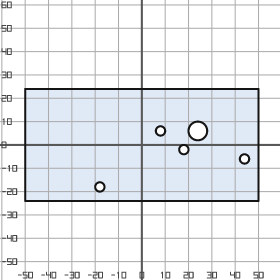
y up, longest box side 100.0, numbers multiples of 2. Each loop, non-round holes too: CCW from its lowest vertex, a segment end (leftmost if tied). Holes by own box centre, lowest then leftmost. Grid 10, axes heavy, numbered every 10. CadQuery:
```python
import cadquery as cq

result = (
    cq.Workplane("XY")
    .moveTo(-50.0, -24.0)
    .lineTo(50.0, -24.0)
    .lineTo(50.0, 24.0)
    .lineTo(-50.0, 24.0)
    .close()
    .moveTo(-18.0, -18.0)
    .circle(2.0)
    .moveTo(44.0, -6.0)
    .circle(2.0)
    .moveTo(18.0, -2.0)
    .circle(2.0)
    .moveTo(8.0, 6.0)
    .circle(2.0)
    .moveTo(24.0, 6.0)
    .circle(4.0)
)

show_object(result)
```